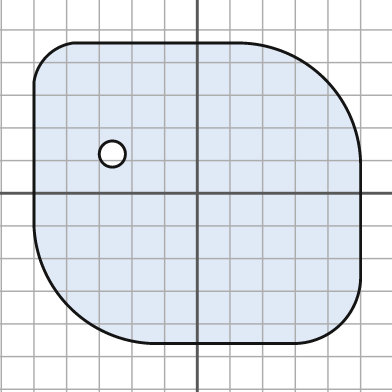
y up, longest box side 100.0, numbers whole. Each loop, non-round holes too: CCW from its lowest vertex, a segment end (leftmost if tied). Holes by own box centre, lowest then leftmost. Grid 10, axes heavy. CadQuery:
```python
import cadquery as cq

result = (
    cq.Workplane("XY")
    .moveTo(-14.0, -46.0)
    .lineTo(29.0, -46.0)
    .threePointArc((44.0, -40.0), (50.0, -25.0))
    .lineTo(50.0, 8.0)
    .threePointArc((39.0, 35.0), (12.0, 46.0))
    .lineTo(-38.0, 46.0)
    .threePointArc((-46.0, 42.0), (-50.0, 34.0))
    .lineTo(-50.0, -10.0)
    .threePointArc((-39.0, -35.0), (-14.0, -46.0))
    .close()
    .moveTo(-26.0, 12.0)
    .circle(4.0)
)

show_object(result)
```